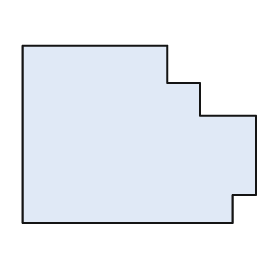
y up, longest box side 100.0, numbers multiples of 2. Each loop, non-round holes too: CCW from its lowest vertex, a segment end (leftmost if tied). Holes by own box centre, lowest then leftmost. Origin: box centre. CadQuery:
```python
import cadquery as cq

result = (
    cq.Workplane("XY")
    .moveTo(-50.0, -38.0)
    .lineTo(40.0, -38.0)
    .lineTo(40.0, -26.0)
    .lineTo(50.0, -26.0)
    .lineTo(50.0, 8.0)
    .lineTo(26.0, 8.0)
    .lineTo(26.0, 22.0)
    .lineTo(12.0, 22.0)
    .lineTo(12.0, 38.0)
    .lineTo(-50.0, 38.0)
    .close()
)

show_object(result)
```